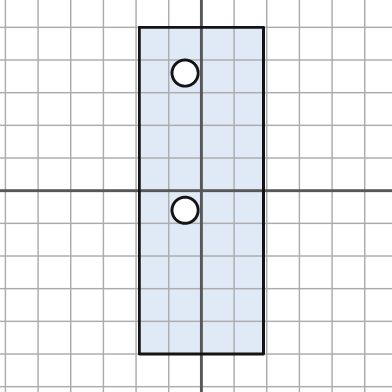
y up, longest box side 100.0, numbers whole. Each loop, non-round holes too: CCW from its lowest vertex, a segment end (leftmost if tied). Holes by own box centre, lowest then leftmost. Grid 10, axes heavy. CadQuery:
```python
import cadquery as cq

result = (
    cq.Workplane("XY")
    .moveTo(-19.0, -50.0)
    .lineTo(19.0, -50.0)
    .lineTo(19.0, 50.0)
    .lineTo(-19.0, 50.0)
    .close()
    .moveTo(-5.0, -6.0)
    .circle(4.0)
    .moveTo(-5.0, 36.0)
    .circle(4.0)
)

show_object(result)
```